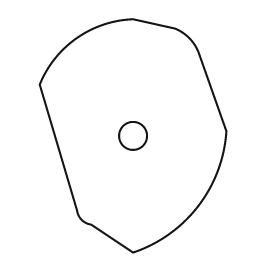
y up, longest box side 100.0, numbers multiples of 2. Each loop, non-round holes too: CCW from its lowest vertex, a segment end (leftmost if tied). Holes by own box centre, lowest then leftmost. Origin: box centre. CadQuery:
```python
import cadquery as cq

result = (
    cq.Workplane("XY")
    .moveTo(0.0, -50.0)
    .threePointArc((28.0, -30.0), (40.0, 2.0))
    .lineTo(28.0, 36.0)
    .threePointArc((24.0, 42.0), (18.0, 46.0))
    .lineTo(0.0, 50.0)
    .threePointArc((-24.0, 42.0), (-40.0, 22.0))
    .lineTo(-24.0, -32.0)
    .threePointArc((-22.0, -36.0), (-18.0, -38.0))
    .close()
    .moveTo(0.0, 0.0)
    .circle(6.0)
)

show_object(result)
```